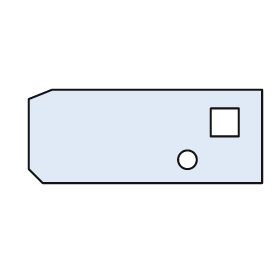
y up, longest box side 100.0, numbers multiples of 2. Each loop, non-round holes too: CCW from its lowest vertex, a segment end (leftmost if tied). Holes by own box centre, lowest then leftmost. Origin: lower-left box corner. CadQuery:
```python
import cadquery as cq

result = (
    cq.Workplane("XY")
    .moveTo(6.0, 0.0)
    .lineTo(100.0, 0.0)
    .lineTo(100.0, 40.0)
    .lineTo(10.0, 40.0)
    .lineTo(0.0, 36.0)
    .lineTo(0.0, 6.0)
    .close()
    .moveTo(68.0, 10.0)
    .circle(4.0)
    .moveTo(78.0, 20.0)
    .lineTo(90.0, 20.0)
    .lineTo(90.0, 32.0)
    .lineTo(78.0, 32.0)
    .close()
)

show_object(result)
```